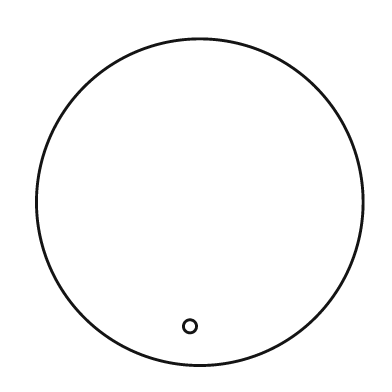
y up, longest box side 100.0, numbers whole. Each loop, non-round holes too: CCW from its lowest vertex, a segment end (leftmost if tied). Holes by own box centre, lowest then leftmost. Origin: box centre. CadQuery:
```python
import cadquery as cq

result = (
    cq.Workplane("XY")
    .moveTo(0.0, 0.0)
    .circle(50.0)
    .moveTo(-3.0, -38.0)
    .circle(2.0)
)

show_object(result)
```